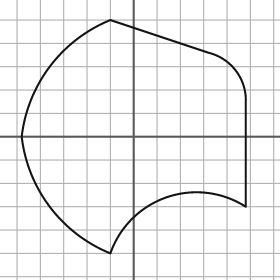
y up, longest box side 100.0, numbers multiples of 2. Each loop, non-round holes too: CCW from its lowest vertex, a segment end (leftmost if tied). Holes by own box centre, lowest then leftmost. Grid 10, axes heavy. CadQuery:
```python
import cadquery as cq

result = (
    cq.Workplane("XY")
    .moveTo(-10.0, -50.0)
    .threePointArc((14.0, -26.0), (48.0, -30.0))
    .lineTo(48.0, 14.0)
    .threePointArc((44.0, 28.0), (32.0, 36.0))
    .lineTo(-10.0, 50.0)
    .threePointArc((-36.0, 30.0), (-48.0, 0.0))
    .threePointArc((-36.0, -30.0), (-10.0, -50.0))
    .close()
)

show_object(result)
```